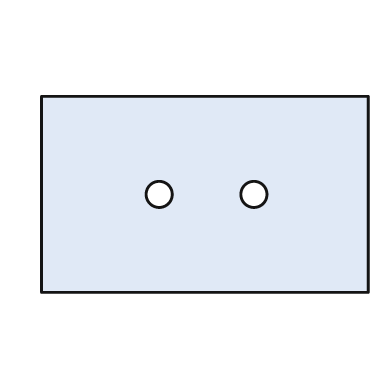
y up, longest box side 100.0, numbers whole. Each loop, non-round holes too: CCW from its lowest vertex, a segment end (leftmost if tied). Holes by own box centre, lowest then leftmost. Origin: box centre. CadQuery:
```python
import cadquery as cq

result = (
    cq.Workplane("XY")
    .moveTo(-50.0, -30.0)
    .lineTo(50.0, -30.0)
    .lineTo(50.0, 30.0)
    .lineTo(-50.0, 30.0)
    .close()
    .moveTo(-14.0, 0.0)
    .circle(4.0)
    .moveTo(15.0, 0.0)
    .circle(4.0)
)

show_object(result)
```